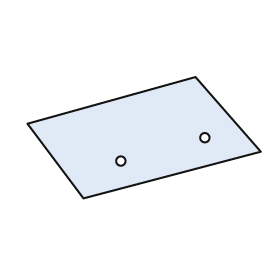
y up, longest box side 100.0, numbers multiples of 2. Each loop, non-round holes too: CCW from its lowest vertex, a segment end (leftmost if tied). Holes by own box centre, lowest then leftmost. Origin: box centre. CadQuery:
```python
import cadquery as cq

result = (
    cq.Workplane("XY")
    .moveTo(-26.0, -26.0)
    .lineTo(50.0, -6.0)
    .lineTo(22.0, 26.0)
    .lineTo(-50.0, 6.0)
    .close()
    .moveTo(-10.0, -10.0)
    .circle(2.0)
    .moveTo(26.0, 0.0)
    .circle(2.0)
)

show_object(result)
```